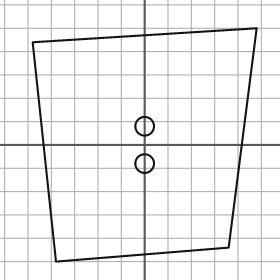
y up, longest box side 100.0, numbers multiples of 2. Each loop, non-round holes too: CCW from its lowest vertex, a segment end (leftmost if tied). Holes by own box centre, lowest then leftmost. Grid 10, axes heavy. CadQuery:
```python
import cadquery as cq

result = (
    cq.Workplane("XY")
    .moveTo(-38.0, -50.0)
    .lineTo(36.0, -44.0)
    .lineTo(48.0, 50.0)
    .lineTo(-48.0, 44.0)
    .close()
    .moveTo(0.0, -8.0)
    .circle(4.0)
    .moveTo(0.0, 8.0)
    .circle(4.0)
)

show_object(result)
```